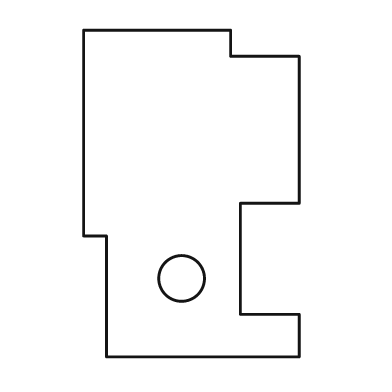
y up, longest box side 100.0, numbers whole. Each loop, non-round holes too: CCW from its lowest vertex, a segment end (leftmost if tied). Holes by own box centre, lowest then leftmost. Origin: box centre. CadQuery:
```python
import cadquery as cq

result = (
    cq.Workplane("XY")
    .moveTo(-26.0, -50.0)
    .lineTo(33.0, -50.0)
    .lineTo(33.0, -37.0)
    .lineTo(15.0, -37.0)
    .lineTo(15.0, -3.0)
    .lineTo(33.0, -3.0)
    .lineTo(33.0, 42.0)
    .lineTo(12.0, 42.0)
    .lineTo(12.0, 50.0)
    .lineTo(-33.0, 50.0)
    .lineTo(-33.0, -13.0)
    .lineTo(-26.0, -13.0)
    .close()
    .moveTo(-3.0, -26.0)
    .circle(7.0)
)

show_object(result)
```